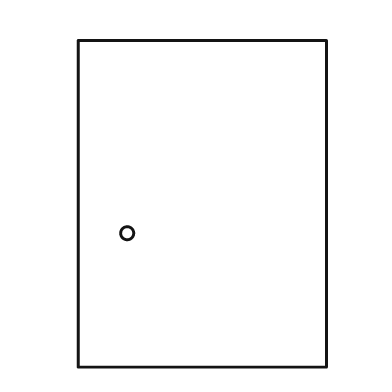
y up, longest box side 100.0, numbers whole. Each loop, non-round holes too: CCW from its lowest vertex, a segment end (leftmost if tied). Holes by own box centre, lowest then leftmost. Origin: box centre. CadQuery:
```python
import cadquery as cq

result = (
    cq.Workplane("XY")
    .moveTo(-38.0, -50.0)
    .lineTo(38.0, -50.0)
    .lineTo(38.0, 50.0)
    .lineTo(-38.0, 50.0)
    .close()
    .moveTo(-23.0, -9.0)
    .circle(2.0)
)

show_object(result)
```